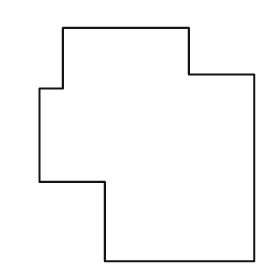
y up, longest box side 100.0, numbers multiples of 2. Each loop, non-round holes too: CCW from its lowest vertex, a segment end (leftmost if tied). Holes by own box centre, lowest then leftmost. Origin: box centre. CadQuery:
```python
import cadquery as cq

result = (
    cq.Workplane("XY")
    .moveTo(-18.0, -50.0)
    .lineTo(46.0, -50.0)
    .lineTo(46.0, 30.0)
    .lineTo(18.0, 30.0)
    .lineTo(18.0, 50.0)
    .lineTo(-36.0, 50.0)
    .lineTo(-36.0, 24.0)
    .lineTo(-46.0, 24.0)
    .lineTo(-46.0, -16.0)
    .lineTo(-18.0, -16.0)
    .close()
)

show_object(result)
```